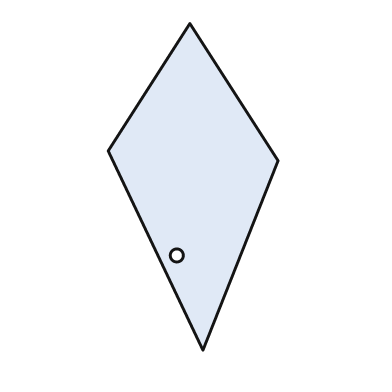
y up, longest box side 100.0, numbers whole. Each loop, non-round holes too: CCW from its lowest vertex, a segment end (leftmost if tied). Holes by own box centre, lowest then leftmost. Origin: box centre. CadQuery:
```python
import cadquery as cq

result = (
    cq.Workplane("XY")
    .moveTo(3.0, -50.0)
    .lineTo(26.0, 8.0)
    .lineTo(-1.0, 50.0)
    .lineTo(-26.0, 11.0)
    .close()
    .moveTo(-5.0, -21.0)
    .circle(2.0)
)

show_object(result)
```